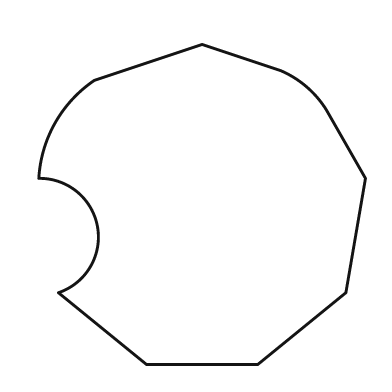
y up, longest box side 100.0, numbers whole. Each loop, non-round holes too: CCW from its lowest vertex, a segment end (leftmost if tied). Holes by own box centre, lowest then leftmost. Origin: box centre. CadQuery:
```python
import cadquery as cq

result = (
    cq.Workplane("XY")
    .moveTo(-17.0, -49.0)
    .lineTo(17.0, -49.0)
    .lineTo(44.0, -27.0)
    .lineTo(50.0, 8.0)
    .lineTo(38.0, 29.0)
    .threePointArc((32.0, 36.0), (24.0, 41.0))
    .lineTo(0.0, 49.0)
    .lineTo(-33.0, 38.0)
    .threePointArc((-45.0, 25.0), (-50.0, 8.0))
    .threePointArc((-32.0, -7.0), (-44.0, -27.0))
    .close()
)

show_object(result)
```